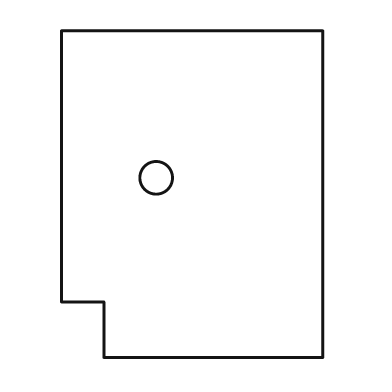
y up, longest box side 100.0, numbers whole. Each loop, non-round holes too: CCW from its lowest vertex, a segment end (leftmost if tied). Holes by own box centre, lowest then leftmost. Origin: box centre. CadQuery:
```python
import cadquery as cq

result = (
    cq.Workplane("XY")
    .moveTo(-27.0, -50.0)
    .lineTo(40.0, -50.0)
    .lineTo(40.0, 50.0)
    .lineTo(-40.0, 50.0)
    .lineTo(-40.0, -33.0)
    .lineTo(-27.0, -33.0)
    .close()
    .moveTo(-11.0, 5.0)
    .circle(5.0)
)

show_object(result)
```